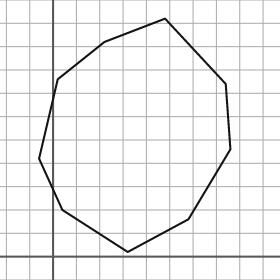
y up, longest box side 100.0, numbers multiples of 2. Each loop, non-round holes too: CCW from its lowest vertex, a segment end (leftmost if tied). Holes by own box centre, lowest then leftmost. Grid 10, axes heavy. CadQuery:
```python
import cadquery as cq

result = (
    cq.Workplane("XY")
    .moveTo(32.0, 2.0)
    .lineTo(58.0, 16.0)
    .lineTo(76.0, 46.0)
    .lineTo(74.0, 74.0)
    .lineTo(48.0, 102.0)
    .lineTo(22.0, 92.0)
    .lineTo(2.0, 76.0)
    .lineTo(-6.0, 42.0)
    .lineTo(4.0, 20.0)
    .close()
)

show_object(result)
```